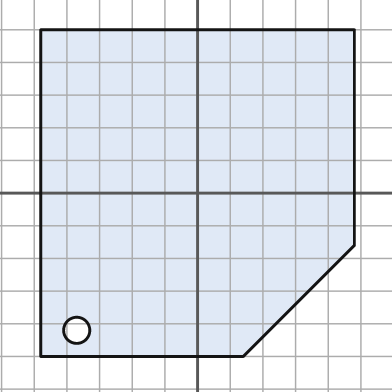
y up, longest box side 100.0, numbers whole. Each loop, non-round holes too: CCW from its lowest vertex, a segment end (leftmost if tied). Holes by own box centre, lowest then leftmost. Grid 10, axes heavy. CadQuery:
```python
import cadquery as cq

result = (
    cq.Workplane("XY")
    .moveTo(-48.0, -50.0)
    .lineTo(14.0, -50.0)
    .lineTo(48.0, -16.0)
    .lineTo(48.0, 50.0)
    .lineTo(-48.0, 50.0)
    .close()
    .moveTo(-37.0, -42.0)
    .circle(4.0)
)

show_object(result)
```